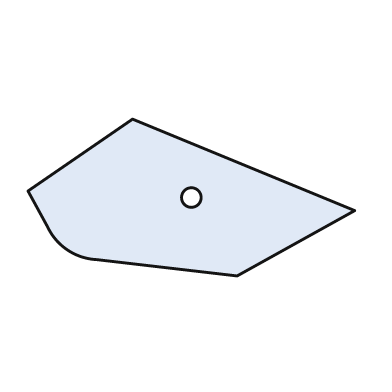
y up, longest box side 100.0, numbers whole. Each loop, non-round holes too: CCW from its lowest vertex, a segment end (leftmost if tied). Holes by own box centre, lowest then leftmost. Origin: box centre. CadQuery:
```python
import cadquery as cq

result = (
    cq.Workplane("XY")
    .moveTo(14.0, -24.0)
    .lineTo(50.0, -4.0)
    .lineTo(-18.0, 24.0)
    .lineTo(-50.0, 2.0)
    .lineTo(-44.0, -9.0)
    .threePointArc((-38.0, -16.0), (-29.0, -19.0))
    .close()
    .moveTo(0.0, 0.0)
    .circle(3.0)
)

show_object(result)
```